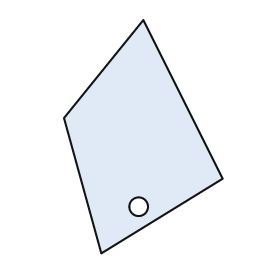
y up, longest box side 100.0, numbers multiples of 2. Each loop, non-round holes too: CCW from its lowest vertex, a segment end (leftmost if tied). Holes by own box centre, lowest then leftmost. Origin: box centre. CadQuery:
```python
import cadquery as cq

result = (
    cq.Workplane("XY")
    .moveTo(-18.0, -50.0)
    .lineTo(34.0, -18.0)
    .lineTo(0.0, 50.0)
    .lineTo(-34.0, 8.0)
    .close()
    .moveTo(-2.0, -30.0)
    .circle(4.0)
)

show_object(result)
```